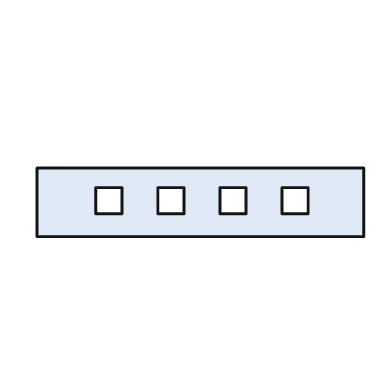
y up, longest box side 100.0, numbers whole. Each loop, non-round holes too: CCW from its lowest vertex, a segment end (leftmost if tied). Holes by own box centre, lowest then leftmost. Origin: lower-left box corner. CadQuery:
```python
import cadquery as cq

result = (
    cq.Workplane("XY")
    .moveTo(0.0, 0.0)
    .lineTo(100.0, 0.0)
    .lineTo(100.0, 21.0)
    .lineTo(0.0, 21.0)
    .close()
    .moveTo(18.0, 7.0)
    .lineTo(26.0, 7.0)
    .lineTo(26.0, 15.0)
    .lineTo(18.0, 15.0)
    .close()
    .moveTo(37.0, 7.0)
    .lineTo(45.0, 7.0)
    .lineTo(45.0, 15.0)
    .lineTo(37.0, 15.0)
    .close()
    .moveTo(56.0, 7.0)
    .lineTo(64.0, 7.0)
    .lineTo(64.0, 15.0)
    .lineTo(56.0, 15.0)
    .close()
    .moveTo(75.0, 7.0)
    .lineTo(83.0, 7.0)
    .lineTo(83.0, 15.0)
    .lineTo(75.0, 15.0)
    .close()
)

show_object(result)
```